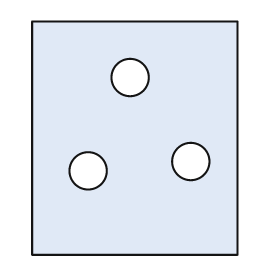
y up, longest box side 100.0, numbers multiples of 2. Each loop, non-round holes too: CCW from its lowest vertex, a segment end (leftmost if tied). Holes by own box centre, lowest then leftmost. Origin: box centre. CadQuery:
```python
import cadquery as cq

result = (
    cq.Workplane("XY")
    .moveTo(-44.0, -50.0)
    .lineTo(44.0, -50.0)
    .lineTo(44.0, 50.0)
    .lineTo(-44.0, 50.0)
    .close()
    .moveTo(-20.0, -14.0)
    .circle(8.0)
    .moveTo(24.0, -10.0)
    .circle(8.0)
    .moveTo(-2.0, 26.0)
    .circle(8.0)
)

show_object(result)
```